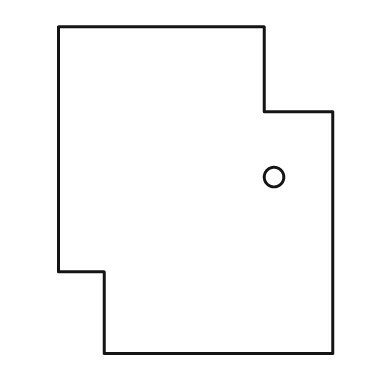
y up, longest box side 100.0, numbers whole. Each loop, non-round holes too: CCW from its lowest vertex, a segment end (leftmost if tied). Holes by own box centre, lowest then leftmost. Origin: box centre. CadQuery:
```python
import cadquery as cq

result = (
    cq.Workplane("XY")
    .moveTo(-28.0, -50.0)
    .lineTo(42.0, -50.0)
    .lineTo(42.0, 24.0)
    .lineTo(21.0, 24.0)
    .lineTo(21.0, 50.0)
    .lineTo(-42.0, 50.0)
    .lineTo(-42.0, -25.0)
    .lineTo(-28.0, -25.0)
    .close()
    .moveTo(24.0, 4.0)
    .circle(3.0)
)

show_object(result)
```